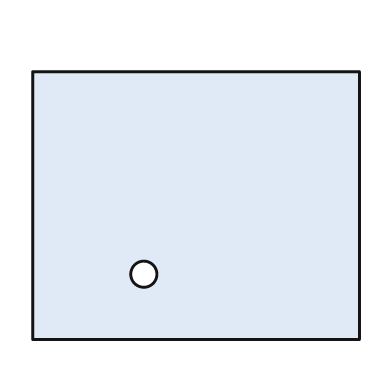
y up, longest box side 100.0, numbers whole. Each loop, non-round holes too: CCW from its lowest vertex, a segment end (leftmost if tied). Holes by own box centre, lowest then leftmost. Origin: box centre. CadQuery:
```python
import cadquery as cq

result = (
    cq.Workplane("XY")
    .moveTo(-50.0, -41.0)
    .lineTo(50.0, -41.0)
    .lineTo(50.0, 41.0)
    .lineTo(-50.0, 41.0)
    .close()
    .moveTo(-16.0, -21.0)
    .circle(4.0)
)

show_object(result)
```